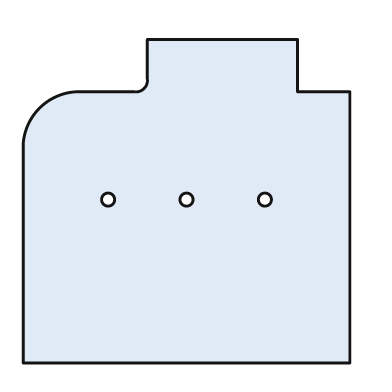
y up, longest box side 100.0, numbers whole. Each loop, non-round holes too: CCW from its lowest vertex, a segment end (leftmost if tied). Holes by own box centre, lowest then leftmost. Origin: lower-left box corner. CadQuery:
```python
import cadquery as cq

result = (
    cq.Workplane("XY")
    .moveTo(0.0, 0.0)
    .lineTo(100.0, 0.0)
    .lineTo(100.0, 83.0)
    .lineTo(84.0, 83.0)
    .lineTo(84.0, 99.0)
    .lineTo(38.0, 99.0)
    .lineTo(38.0, 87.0)
    .threePointArc((37.0, 84.0), (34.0, 83.0))
    .lineTo(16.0, 83.0)
    .threePointArc((5.0, 78.0), (0.0, 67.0))
    .close()
    .moveTo(26.0, 50.0)
    .circle(2.0)
    .moveTo(50.0, 50.0)
    .circle(2.0)
    .moveTo(74.0, 50.0)
    .circle(2.0)
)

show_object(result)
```